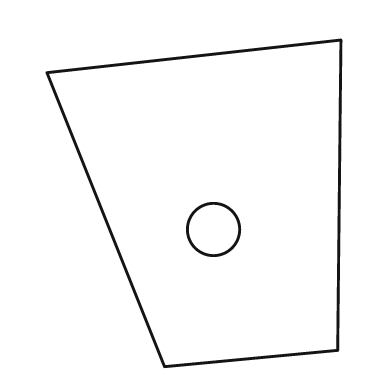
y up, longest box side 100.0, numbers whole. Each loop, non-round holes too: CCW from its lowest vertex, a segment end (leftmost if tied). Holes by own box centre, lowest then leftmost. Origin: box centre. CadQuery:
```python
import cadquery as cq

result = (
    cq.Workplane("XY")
    .moveTo(-9.0, -50.0)
    .lineTo(44.0, -45.0)
    .lineTo(45.0, 50.0)
    .lineTo(-45.0, 40.0)
    .close()
    .moveTo(6.0, -8.0)
    .circle(8.0)
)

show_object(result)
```